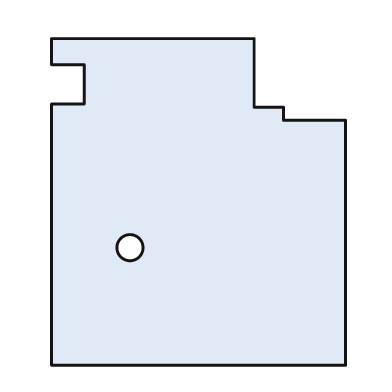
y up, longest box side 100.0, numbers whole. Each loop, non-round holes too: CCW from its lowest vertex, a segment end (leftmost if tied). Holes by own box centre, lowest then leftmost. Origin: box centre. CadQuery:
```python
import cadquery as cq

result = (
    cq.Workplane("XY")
    .moveTo(-45.0, -50.0)
    .lineTo(45.0, -50.0)
    .lineTo(45.0, 25.0)
    .lineTo(26.0, 25.0)
    .lineTo(26.0, 29.0)
    .lineTo(17.0, 29.0)
    .lineTo(17.0, 50.0)
    .lineTo(-45.0, 50.0)
    .lineTo(-45.0, 42.0)
    .lineTo(-35.0, 42.0)
    .lineTo(-35.0, 30.0)
    .lineTo(-45.0, 30.0)
    .close()
    .moveTo(-21.0, -14.0)
    .circle(4.0)
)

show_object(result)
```